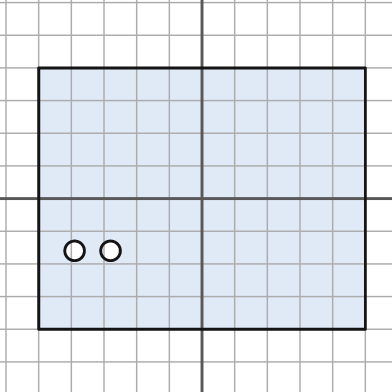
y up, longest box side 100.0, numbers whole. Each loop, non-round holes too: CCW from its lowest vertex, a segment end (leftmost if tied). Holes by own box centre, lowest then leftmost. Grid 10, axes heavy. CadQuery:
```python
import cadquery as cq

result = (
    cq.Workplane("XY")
    .moveTo(-50.0, -40.0)
    .lineTo(50.0, -40.0)
    .lineTo(50.0, 40.0)
    .lineTo(-50.0, 40.0)
    .close()
    .moveTo(-39.0, -16.0)
    .circle(3.0)
    .moveTo(-28.0, -16.0)
    .circle(3.0)
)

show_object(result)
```